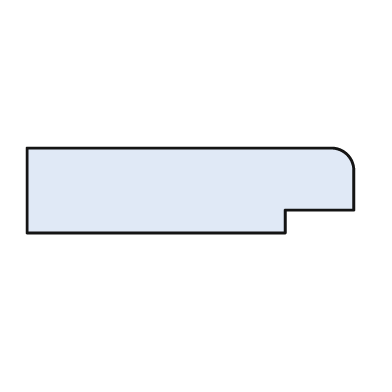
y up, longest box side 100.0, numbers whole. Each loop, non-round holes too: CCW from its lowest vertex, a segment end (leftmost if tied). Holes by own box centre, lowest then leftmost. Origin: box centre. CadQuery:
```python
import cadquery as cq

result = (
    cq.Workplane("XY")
    .moveTo(-50.0, -13.0)
    .lineTo(29.0, -13.0)
    .lineTo(29.0, -6.0)
    .lineTo(50.0, -6.0)
    .lineTo(50.0, 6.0)
    .threePointArc((48.0, 11.0), (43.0, 13.0))
    .lineTo(-50.0, 13.0)
    .close()
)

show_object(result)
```